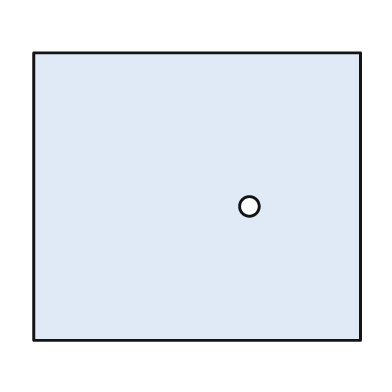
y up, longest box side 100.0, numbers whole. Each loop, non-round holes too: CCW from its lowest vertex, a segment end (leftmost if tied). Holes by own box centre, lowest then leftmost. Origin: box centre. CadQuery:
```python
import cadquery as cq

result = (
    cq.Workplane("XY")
    .moveTo(-50.0, -44.0)
    .lineTo(50.0, -44.0)
    .lineTo(50.0, 44.0)
    .lineTo(-50.0, 44.0)
    .close()
    .moveTo(16.0, -3.0)
    .circle(3.0)
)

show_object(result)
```